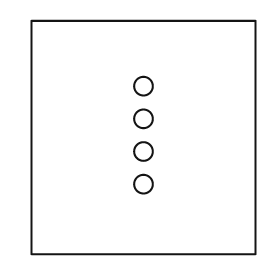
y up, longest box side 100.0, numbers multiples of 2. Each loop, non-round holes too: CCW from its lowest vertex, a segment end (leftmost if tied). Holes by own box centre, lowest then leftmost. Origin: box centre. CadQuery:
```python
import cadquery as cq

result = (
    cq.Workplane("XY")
    .moveTo(-48.0, -50.0)
    .lineTo(48.0, -50.0)
    .lineTo(48.0, 50.0)
    .lineTo(-48.0, 50.0)
    .close()
    .moveTo(0.0, -20.0)
    .circle(4.0)
    .moveTo(0.0, -6.0)
    .circle(4.0)
    .moveTo(0.0, 8.0)
    .circle(4.0)
    .moveTo(0.0, 22.0)
    .circle(4.0)
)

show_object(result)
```